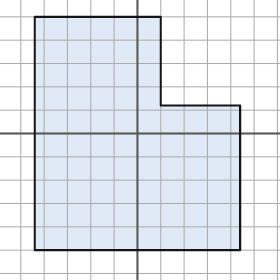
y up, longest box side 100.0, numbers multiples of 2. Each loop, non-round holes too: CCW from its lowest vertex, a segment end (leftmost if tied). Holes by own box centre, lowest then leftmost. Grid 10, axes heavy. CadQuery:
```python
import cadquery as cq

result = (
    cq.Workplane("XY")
    .moveTo(-44.0, -50.0)
    .lineTo(44.0, -50.0)
    .lineTo(44.0, 12.0)
    .lineTo(10.0, 12.0)
    .lineTo(10.0, 50.0)
    .lineTo(-44.0, 50.0)
    .close()
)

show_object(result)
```